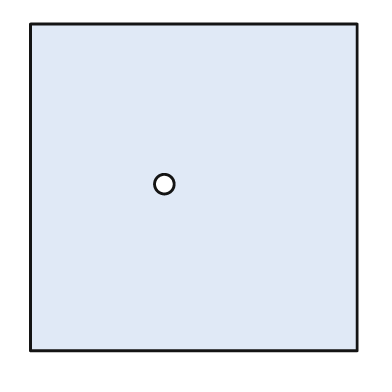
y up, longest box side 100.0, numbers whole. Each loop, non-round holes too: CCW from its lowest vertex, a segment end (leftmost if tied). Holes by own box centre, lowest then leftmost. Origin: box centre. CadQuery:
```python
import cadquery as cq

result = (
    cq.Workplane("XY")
    .moveTo(-50.0, -50.0)
    .lineTo(50.0, -50.0)
    .lineTo(50.0, 50.0)
    .lineTo(-50.0, 50.0)
    .close()
    .moveTo(-9.0, 1.0)
    .circle(3.0)
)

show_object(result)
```